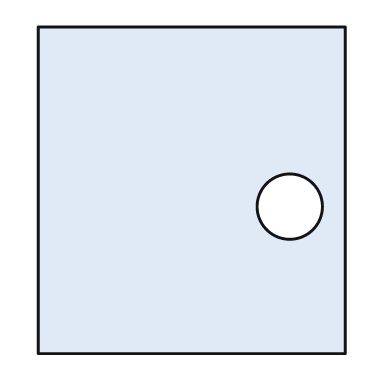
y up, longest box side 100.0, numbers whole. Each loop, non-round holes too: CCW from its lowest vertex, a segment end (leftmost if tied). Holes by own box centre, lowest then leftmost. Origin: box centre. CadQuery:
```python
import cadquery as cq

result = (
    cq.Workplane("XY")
    .moveTo(-47.0, -50.0)
    .lineTo(47.0, -50.0)
    .lineTo(47.0, 50.0)
    .lineTo(-47.0, 50.0)
    .close()
    .moveTo(30.0, -5.0)
    .circle(10.0)
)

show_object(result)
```